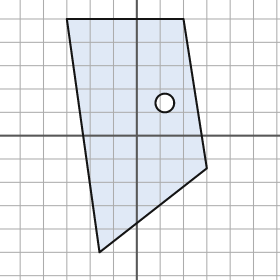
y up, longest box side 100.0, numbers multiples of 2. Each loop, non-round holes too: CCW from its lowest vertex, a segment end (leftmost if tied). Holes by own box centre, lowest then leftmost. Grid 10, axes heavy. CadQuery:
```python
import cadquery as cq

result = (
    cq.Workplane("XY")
    .moveTo(-16.0, -50.0)
    .lineTo(30.0, -14.0)
    .lineTo(20.0, 50.0)
    .lineTo(-30.0, 50.0)
    .close()
    .moveTo(12.0, 14.0)
    .circle(4.0)
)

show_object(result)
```